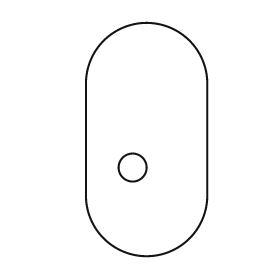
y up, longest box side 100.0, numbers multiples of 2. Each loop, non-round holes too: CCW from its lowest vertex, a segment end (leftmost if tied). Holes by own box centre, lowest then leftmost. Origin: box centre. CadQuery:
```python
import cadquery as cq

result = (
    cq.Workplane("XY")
    .moveTo(-26.0, -24.0)
    .threePointArc((0.0, -50.0), (26.0, -24.0))
    .lineTo(26.0, 24.0)
    .threePointArc((0.0, 50.0), (-26.0, 24.0))
    .close()
    .moveTo(-6.0, -12.0)
    .circle(6.0)
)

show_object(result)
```